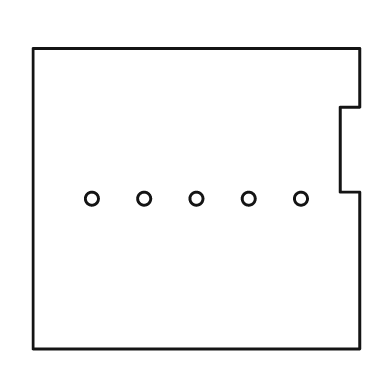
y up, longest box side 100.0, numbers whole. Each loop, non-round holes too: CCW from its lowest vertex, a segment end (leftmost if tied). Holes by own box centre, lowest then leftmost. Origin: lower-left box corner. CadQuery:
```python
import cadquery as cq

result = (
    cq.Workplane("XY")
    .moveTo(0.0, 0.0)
    .lineTo(100.0, 0.0)
    .lineTo(100.0, 48.0)
    .lineTo(94.0, 48.0)
    .lineTo(94.0, 74.0)
    .lineTo(100.0, 74.0)
    .lineTo(100.0, 92.0)
    .lineTo(0.0, 92.0)
    .close()
    .moveTo(18.0, 46.0)
    .circle(2.0)
    .moveTo(34.0, 46.0)
    .circle(2.0)
    .moveTo(50.0, 46.0)
    .circle(2.0)
    .moveTo(66.0, 46.0)
    .circle(2.0)
    .moveTo(82.0, 46.0)
    .circle(2.0)
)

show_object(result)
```